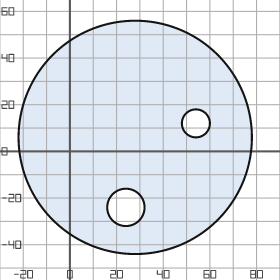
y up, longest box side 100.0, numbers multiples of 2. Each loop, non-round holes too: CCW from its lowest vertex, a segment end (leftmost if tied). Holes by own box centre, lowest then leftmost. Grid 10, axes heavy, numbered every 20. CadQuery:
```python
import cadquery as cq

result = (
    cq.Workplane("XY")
    .moveTo(28.0, 6.0)
    .circle(50.0)
    .moveTo(24.0, -24.0)
    .circle(8.0)
    .moveTo(54.0, 12.0)
    .circle(6.0)
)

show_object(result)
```